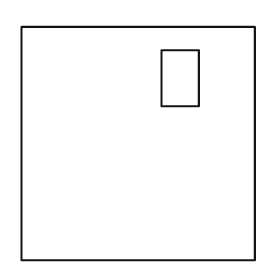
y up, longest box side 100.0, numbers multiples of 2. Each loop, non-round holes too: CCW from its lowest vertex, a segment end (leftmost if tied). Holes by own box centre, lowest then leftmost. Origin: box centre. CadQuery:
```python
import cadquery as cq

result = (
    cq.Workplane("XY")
    .moveTo(-50.0, -50.0)
    .lineTo(50.0, -50.0)
    .lineTo(50.0, 50.0)
    .lineTo(-50.0, 50.0)
    .close()
    .moveTo(10.0, 16.0)
    .lineTo(26.0, 16.0)
    .lineTo(26.0, 40.0)
    .lineTo(10.0, 40.0)
    .close()
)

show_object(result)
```